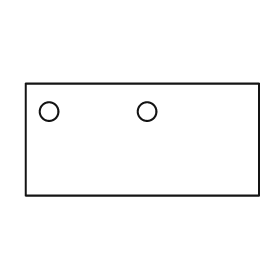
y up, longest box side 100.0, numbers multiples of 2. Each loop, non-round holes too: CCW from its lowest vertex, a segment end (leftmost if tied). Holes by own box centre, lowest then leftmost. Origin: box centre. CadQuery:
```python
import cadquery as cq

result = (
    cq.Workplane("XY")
    .moveTo(-50.0, -24.0)
    .lineTo(50.0, -24.0)
    .lineTo(50.0, 24.0)
    .lineTo(-50.0, 24.0)
    .close()
    .moveTo(-40.0, 12.0)
    .circle(4.0)
    .moveTo(2.0, 12.0)
    .circle(4.0)
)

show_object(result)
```